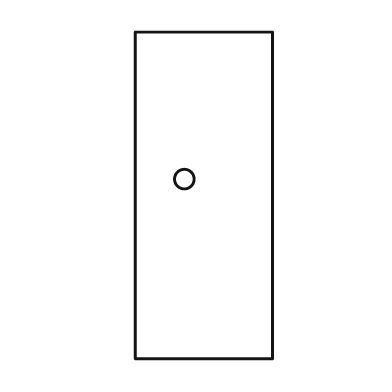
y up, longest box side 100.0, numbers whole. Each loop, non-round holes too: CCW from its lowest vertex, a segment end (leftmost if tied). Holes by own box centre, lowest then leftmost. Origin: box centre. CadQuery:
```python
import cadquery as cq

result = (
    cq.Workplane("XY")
    .moveTo(-21.0, -50.0)
    .lineTo(21.0, -50.0)
    .lineTo(21.0, 50.0)
    .lineTo(-21.0, 50.0)
    .close()
    .moveTo(-6.0, 5.0)
    .circle(3.0)
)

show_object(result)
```